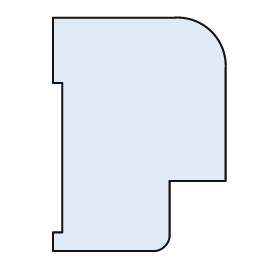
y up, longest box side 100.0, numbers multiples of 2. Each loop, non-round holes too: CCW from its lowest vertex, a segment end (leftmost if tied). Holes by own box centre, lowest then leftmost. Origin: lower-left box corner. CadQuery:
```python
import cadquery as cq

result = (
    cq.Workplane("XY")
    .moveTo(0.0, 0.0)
    .lineTo(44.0, 0.0)
    .threePointArc((48.0, 2.0), (50.0, 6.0))
    .lineTo(50.0, 30.0)
    .lineTo(74.0, 30.0)
    .lineTo(74.0, 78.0)
    .threePointArc((68.0, 94.0), (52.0, 100.0))
    .lineTo(0.0, 100.0)
    .lineTo(0.0, 72.0)
    .lineTo(4.0, 72.0)
    .lineTo(4.0, 8.0)
    .lineTo(0.0, 8.0)
    .close()
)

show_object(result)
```